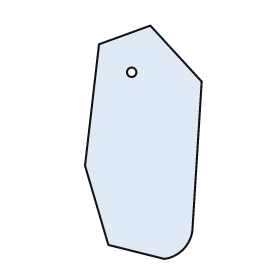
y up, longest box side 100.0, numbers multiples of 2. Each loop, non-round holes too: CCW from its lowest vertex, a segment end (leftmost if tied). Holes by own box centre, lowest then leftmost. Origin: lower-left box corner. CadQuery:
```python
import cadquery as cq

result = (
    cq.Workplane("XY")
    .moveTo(34.0, 0.0)
    .threePointArc((42.0, 4.0), (46.0, 12.0))
    .lineTo(50.0, 76.0)
    .lineTo(28.0, 100.0)
    .lineTo(6.0, 92.0)
    .lineTo(0.0, 40.0)
    .lineTo(10.0, 6.0)
    .close()
    .moveTo(20.0, 80.0)
    .circle(2.0)
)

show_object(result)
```